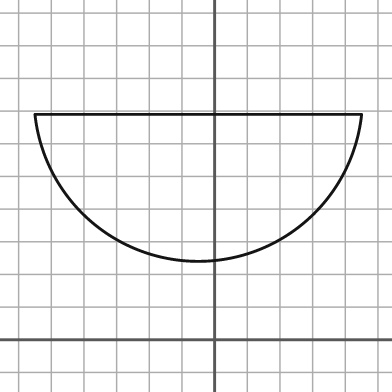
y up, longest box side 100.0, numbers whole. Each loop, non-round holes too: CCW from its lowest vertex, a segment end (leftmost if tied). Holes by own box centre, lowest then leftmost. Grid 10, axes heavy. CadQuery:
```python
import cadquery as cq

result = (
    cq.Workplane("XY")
    .moveTo(-55.0, 69.0)
    .threePointArc((-5.0, 24.0), (45.0, 69.0))
    .close()
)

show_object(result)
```